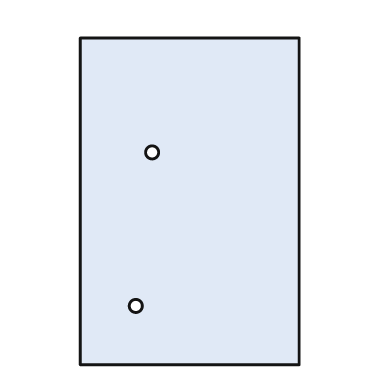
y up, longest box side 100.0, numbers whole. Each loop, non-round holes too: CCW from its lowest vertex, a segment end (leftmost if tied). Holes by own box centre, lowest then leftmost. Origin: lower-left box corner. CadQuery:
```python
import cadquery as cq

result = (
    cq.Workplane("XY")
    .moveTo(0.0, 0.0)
    .lineTo(67.0, 0.0)
    .lineTo(67.0, 100.0)
    .lineTo(0.0, 100.0)
    .close()
    .moveTo(17.0, 18.0)
    .circle(2.0)
    .moveTo(22.0, 65.0)
    .circle(2.0)
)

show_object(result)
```